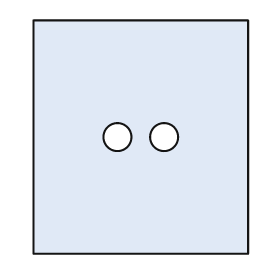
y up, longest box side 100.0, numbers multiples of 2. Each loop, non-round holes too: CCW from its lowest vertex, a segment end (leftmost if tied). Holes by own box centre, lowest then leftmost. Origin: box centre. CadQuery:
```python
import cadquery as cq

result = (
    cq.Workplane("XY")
    .moveTo(-46.0, -50.0)
    .lineTo(46.0, -50.0)
    .lineTo(46.0, 50.0)
    .lineTo(-46.0, 50.0)
    .close()
    .moveTo(-10.0, 0.0)
    .circle(6.0)
    .moveTo(10.0, 0.0)
    .circle(6.0)
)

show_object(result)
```